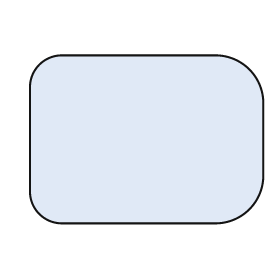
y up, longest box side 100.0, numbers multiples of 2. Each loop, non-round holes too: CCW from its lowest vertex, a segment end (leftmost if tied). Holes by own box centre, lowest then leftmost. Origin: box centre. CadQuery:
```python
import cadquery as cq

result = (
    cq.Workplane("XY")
    .moveTo(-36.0, -36.0)
    .lineTo(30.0, -36.0)
    .threePointArc((44.0, -30.0), (50.0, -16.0))
    .lineTo(50.0, 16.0)
    .threePointArc((44.0, 30.0), (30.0, 36.0))
    .lineTo(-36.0, 36.0)
    .threePointArc((-46.0, 32.0), (-50.0, 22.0))
    .lineTo(-50.0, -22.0)
    .threePointArc((-46.0, -32.0), (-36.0, -36.0))
    .close()
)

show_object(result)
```